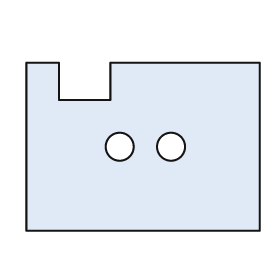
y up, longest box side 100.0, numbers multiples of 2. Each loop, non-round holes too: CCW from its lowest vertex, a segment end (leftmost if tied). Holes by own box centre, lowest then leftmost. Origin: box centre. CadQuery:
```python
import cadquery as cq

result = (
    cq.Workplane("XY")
    .moveTo(-50.0, -36.0)
    .lineTo(50.0, -36.0)
    .lineTo(50.0, 36.0)
    .lineTo(-14.0, 36.0)
    .lineTo(-14.0, 20.0)
    .lineTo(-36.0, 20.0)
    .lineTo(-36.0, 36.0)
    .lineTo(-50.0, 36.0)
    .close()
    .moveTo(-10.0, 0.0)
    .circle(6.0)
    .moveTo(12.0, 0.0)
    .circle(6.0)
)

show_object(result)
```